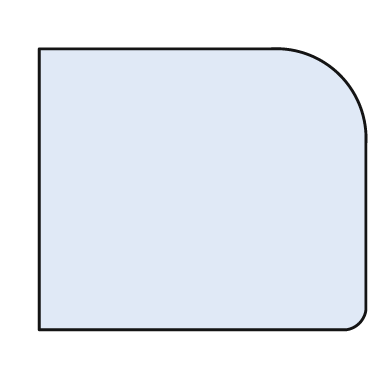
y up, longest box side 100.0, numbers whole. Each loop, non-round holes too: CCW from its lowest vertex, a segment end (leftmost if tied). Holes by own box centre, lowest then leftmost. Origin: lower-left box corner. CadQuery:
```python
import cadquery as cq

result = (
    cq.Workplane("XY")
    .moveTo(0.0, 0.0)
    .lineTo(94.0, 0.0)
    .threePointArc((98.0, 2.0), (100.0, 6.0))
    .lineTo(100.0, 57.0)
    .threePointArc((92.0, 78.0), (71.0, 86.0))
    .lineTo(0.0, 86.0)
    .close()
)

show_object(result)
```